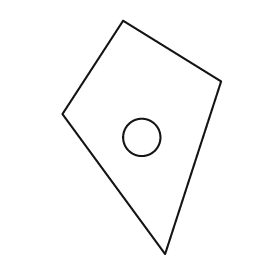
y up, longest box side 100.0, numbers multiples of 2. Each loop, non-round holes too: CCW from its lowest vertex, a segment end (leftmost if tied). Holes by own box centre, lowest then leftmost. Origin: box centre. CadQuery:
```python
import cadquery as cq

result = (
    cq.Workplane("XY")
    .moveTo(10.0, -50.0)
    .lineTo(34.0, 24.0)
    .lineTo(-8.0, 50.0)
    .lineTo(-34.0, 10.0)
    .close()
    .moveTo(0.0, 0.0)
    .circle(8.0)
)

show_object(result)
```